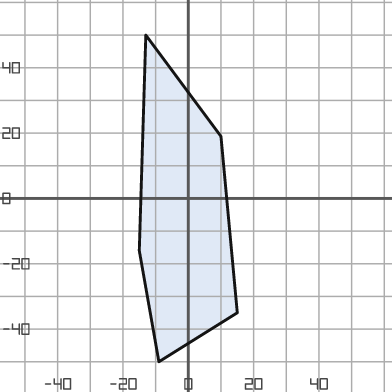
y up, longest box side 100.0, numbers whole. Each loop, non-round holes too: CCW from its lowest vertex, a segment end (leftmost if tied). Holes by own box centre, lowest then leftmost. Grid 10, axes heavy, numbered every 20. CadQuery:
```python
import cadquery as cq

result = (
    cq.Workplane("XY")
    .moveTo(-9.0, -50.0)
    .lineTo(15.0, -35.0)
    .lineTo(10.0, 19.0)
    .lineTo(-13.0, 50.0)
    .lineTo(-15.0, -16.0)
    .close()
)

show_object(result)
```